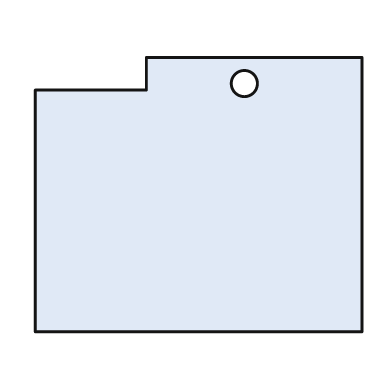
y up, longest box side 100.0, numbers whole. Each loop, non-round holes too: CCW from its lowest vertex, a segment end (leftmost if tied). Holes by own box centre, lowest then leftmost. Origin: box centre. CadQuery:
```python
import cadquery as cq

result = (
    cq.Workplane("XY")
    .moveTo(-50.0, -42.0)
    .lineTo(50.0, -42.0)
    .lineTo(50.0, 42.0)
    .lineTo(-16.0, 42.0)
    .lineTo(-16.0, 32.0)
    .lineTo(-50.0, 32.0)
    .close()
    .moveTo(14.0, 34.0)
    .circle(4.0)
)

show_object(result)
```